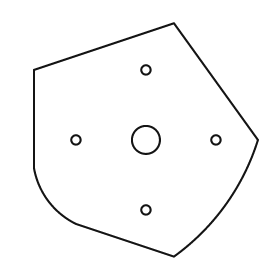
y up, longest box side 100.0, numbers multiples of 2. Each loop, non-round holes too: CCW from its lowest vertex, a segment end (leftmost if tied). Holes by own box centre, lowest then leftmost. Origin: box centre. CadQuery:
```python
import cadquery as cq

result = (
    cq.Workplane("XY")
    .moveTo(12.0, -50.0)
    .threePointArc((34.0, -28.0), (48.0, 0.0))
    .lineTo(12.0, 50.0)
    .lineTo(-48.0, 30.0)
    .lineTo(-48.0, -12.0)
    .threePointArc((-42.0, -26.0), (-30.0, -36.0))
    .close()
    .moveTo(0.0, -30.0)
    .circle(2.0)
    .moveTo(-30.0, 0.0)
    .circle(2.0)
    .moveTo(0.0, 0.0)
    .circle(6.0)
    .moveTo(30.0, 0.0)
    .circle(2.0)
    .moveTo(0.0, 30.0)
    .circle(2.0)
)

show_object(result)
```